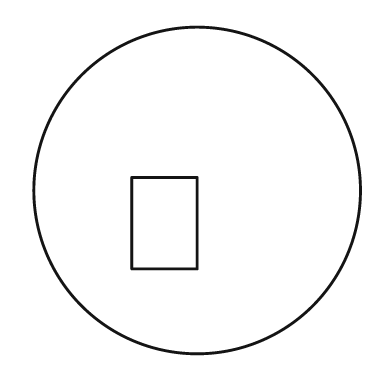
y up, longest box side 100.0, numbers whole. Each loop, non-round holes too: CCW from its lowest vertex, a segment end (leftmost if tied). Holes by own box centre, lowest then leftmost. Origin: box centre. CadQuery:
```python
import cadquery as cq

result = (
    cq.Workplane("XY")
    .moveTo(0.0, 0.0)
    .circle(50.0)
    .moveTo(-20.0, -24.0)
    .lineTo(0.0, -24.0)
    .lineTo(0.0, 4.0)
    .lineTo(-20.0, 4.0)
    .close()
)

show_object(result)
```